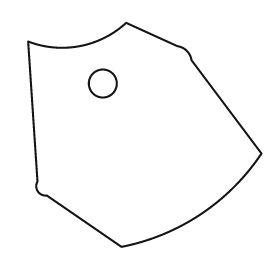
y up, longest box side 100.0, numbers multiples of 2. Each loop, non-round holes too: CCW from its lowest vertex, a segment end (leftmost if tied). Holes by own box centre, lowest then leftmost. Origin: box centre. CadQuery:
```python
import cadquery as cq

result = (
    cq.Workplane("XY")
    .moveTo(-10.0, -48.0)
    .threePointArc((24.0, -34.0), (50.0, -8.0))
    .lineTo(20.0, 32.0)
    .threePointArc((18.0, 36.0), (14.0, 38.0))
    .lineTo(-8.0, 48.0)
    .threePointArc((-28.0, 38.0), (-50.0, 40.0))
    .lineTo(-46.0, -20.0)
    .threePointArc((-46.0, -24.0), (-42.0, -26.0))
    .close()
    .moveTo(-18.0, 22.0)
    .circle(6.0)
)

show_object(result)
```